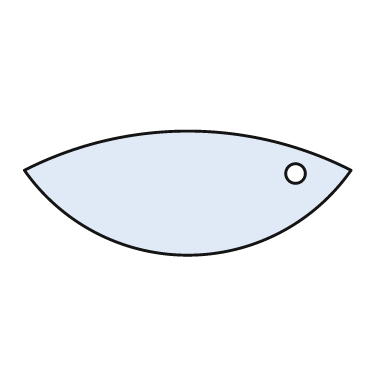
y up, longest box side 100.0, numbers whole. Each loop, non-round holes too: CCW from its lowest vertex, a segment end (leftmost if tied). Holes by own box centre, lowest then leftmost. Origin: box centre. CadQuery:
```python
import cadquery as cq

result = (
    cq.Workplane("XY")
    .moveTo(-50.0, 7.0)
    .threePointArc((0.0, -19.0), (50.0, 7.0))
    .threePointArc((0.0, 19.0), (-50.0, 7.0))
    .close()
    .moveTo(33.0, 6.0)
    .circle(3.0)
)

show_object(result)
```